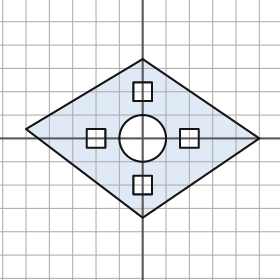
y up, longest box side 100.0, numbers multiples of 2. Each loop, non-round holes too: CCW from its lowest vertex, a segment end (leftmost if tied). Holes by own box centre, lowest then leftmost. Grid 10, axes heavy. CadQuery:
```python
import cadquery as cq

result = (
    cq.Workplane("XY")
    .moveTo(0.0, -34.0)
    .lineTo(50.0, 0.0)
    .lineTo(0.0, 34.0)
    .lineTo(-50.0, 4.0)
    .close()
    .moveTo(-4.0, -24.0)
    .lineTo(4.0, -24.0)
    .lineTo(4.0, -16.0)
    .lineTo(-4.0, -16.0)
    .close()
    .moveTo(-24.0, -4.0)
    .lineTo(-16.0, -4.0)
    .lineTo(-16.0, 4.0)
    .lineTo(-24.0, 4.0)
    .close()
    .moveTo(0.0, 0.0)
    .circle(10.0)
    .moveTo(16.0, -4.0)
    .lineTo(24.0, -4.0)
    .lineTo(24.0, 4.0)
    .lineTo(16.0, 4.0)
    .close()
    .moveTo(-4.0, 16.0)
    .lineTo(4.0, 16.0)
    .lineTo(4.0, 24.0)
    .lineTo(-4.0, 24.0)
    .close()
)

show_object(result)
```